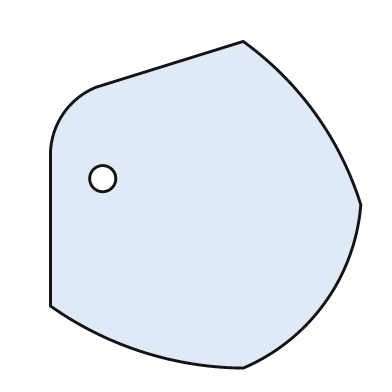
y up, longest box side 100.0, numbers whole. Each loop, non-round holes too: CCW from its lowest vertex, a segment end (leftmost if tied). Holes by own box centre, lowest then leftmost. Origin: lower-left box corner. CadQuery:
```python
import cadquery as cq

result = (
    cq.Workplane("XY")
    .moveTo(59.0, 0.0)
    .threePointArc((84.0, 20.0), (95.0, 50.0))
    .threePointArc((81.0, 78.0), (59.0, 100.0))
    .lineTo(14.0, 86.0)
    .threePointArc((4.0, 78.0), (0.0, 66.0))
    .lineTo(0.0, 19.0)
    .threePointArc((28.0, 5.0), (59.0, 0.0))
    .close()
    .moveTo(16.0, 58.0)
    .circle(4.0)
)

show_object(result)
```